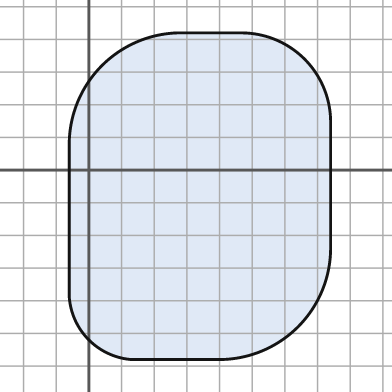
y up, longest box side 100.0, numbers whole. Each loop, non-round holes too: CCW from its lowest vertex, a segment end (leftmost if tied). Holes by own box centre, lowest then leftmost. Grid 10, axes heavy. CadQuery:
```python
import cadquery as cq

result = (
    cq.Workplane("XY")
    .moveTo(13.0, -58.0)
    .lineTo(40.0, -58.0)
    .threePointArc((64.0, -48.0), (74.0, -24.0))
    .lineTo(74.0, 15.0)
    .threePointArc((66.0, 34.0), (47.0, 42.0))
    .lineTo(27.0, 42.0)
    .threePointArc((4.0, 32.0), (-6.0, 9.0))
    .lineTo(-6.0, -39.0)
    .threePointArc((0.0, -52.0), (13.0, -58.0))
    .close()
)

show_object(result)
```